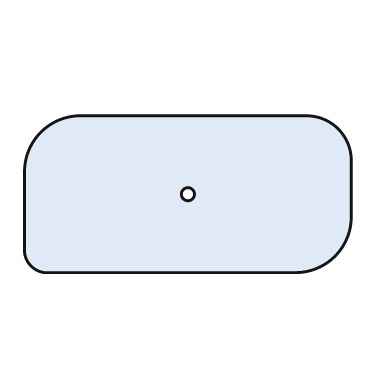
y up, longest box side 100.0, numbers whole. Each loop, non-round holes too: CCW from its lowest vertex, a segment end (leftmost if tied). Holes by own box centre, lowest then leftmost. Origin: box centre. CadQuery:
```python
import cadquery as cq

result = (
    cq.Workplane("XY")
    .moveTo(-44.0, -24.0)
    .lineTo(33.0, -24.0)
    .threePointArc((45.0, -19.0), (50.0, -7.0))
    .lineTo(50.0, 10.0)
    .threePointArc((46.0, 20.0), (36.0, 24.0))
    .lineTo(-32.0, 24.0)
    .threePointArc((-45.0, 19.0), (-50.0, 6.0))
    .lineTo(-50.0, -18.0)
    .threePointArc((-48.0, -22.0), (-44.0, -24.0))
    .close()
    .moveTo(0.0, 0.0)
    .circle(2.0)
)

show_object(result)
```